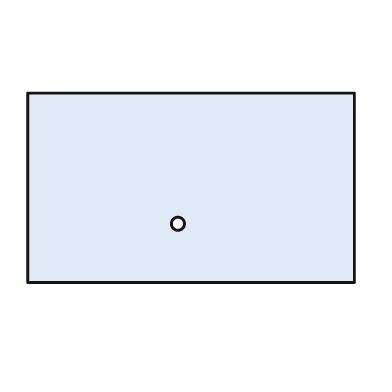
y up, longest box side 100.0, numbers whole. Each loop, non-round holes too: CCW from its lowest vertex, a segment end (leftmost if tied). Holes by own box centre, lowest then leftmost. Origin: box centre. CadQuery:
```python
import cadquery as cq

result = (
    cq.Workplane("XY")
    .moveTo(-50.0, -29.0)
    .lineTo(50.0, -29.0)
    .lineTo(50.0, 29.0)
    .lineTo(-50.0, 29.0)
    .close()
    .moveTo(-4.0, -11.0)
    .circle(2.0)
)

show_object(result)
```